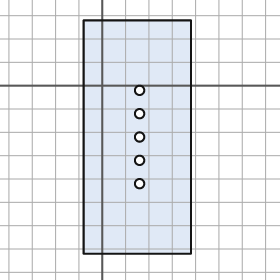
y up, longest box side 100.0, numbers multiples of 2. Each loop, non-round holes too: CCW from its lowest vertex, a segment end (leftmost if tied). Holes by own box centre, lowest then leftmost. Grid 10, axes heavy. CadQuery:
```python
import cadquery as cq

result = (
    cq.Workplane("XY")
    .moveTo(-8.0, -72.0)
    .lineTo(38.0, -72.0)
    .lineTo(38.0, 28.0)
    .lineTo(-8.0, 28.0)
    .close()
    .moveTo(16.0, -42.0)
    .circle(2.0)
    .moveTo(16.0, -32.0)
    .circle(2.0)
    .moveTo(16.0, -22.0)
    .circle(2.0)
    .moveTo(16.0, -12.0)
    .circle(2.0)
    .moveTo(16.0, -2.0)
    .circle(2.0)
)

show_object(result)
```